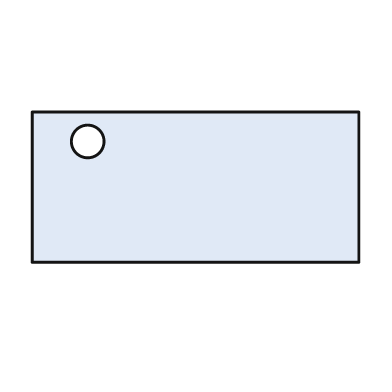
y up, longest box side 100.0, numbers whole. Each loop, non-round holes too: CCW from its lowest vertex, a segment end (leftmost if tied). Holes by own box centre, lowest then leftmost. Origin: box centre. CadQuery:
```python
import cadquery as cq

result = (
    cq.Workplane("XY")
    .moveTo(-50.0, -23.0)
    .lineTo(50.0, -23.0)
    .lineTo(50.0, 23.0)
    .lineTo(-50.0, 23.0)
    .close()
    .moveTo(-33.0, 14.0)
    .circle(5.0)
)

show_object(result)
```